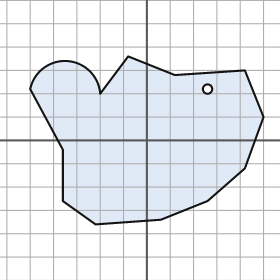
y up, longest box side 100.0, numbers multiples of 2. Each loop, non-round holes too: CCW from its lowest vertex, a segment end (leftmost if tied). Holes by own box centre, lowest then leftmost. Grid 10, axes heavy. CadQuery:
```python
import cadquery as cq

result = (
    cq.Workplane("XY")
    .moveTo(-22.0, -36.0)
    .lineTo(6.0, -34.0)
    .lineTo(26.0, -26.0)
    .lineTo(42.0, -12.0)
    .lineTo(50.0, 10.0)
    .lineTo(42.0, 30.0)
    .lineTo(12.0, 28.0)
    .lineTo(-8.0, 36.0)
    .lineTo(-20.0, 20.0)
    .threePointArc((-34.0, 34.0), (-50.0, 22.0))
    .lineTo(-36.0, -4.0)
    .lineTo(-36.0, -26.0)
    .close()
    .moveTo(26.0, 22.0)
    .circle(2.0)
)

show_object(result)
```